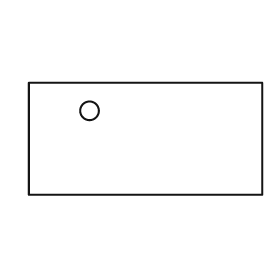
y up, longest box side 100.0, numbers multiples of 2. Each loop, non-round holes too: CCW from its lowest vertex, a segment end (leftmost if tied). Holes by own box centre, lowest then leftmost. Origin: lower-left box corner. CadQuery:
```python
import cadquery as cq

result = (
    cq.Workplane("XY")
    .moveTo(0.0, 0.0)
    .lineTo(100.0, 0.0)
    .lineTo(100.0, 48.0)
    .lineTo(0.0, 48.0)
    .close()
    .moveTo(26.0, 36.0)
    .circle(4.0)
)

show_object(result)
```